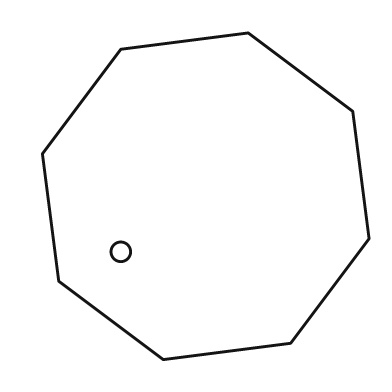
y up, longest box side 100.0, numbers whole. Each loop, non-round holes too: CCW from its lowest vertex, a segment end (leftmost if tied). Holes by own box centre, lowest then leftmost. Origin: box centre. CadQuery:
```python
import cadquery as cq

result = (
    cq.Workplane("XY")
    .moveTo(-13.0, -50.0)
    .lineTo(26.0, -45.0)
    .lineTo(50.0, -13.0)
    .lineTo(45.0, 26.0)
    .lineTo(13.0, 50.0)
    .lineTo(-26.0, 45.0)
    .lineTo(-50.0, 13.0)
    .lineTo(-45.0, -26.0)
    .close()
    .moveTo(-26.0, -17.0)
    .circle(3.0)
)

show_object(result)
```